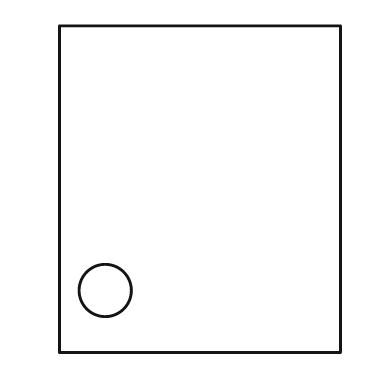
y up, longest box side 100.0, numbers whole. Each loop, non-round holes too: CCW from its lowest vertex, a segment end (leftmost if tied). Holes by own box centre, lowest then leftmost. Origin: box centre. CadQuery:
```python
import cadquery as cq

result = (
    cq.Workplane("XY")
    .moveTo(-43.0, -50.0)
    .lineTo(43.0, -50.0)
    .lineTo(43.0, 50.0)
    .lineTo(-43.0, 50.0)
    .close()
    .moveTo(-29.0, -31.0)
    .circle(8.0)
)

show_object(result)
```